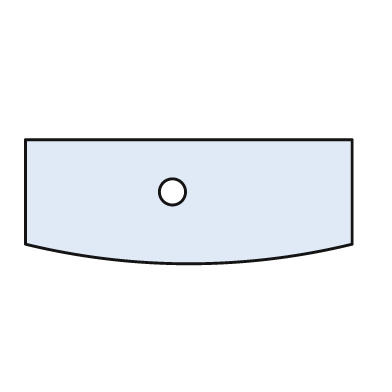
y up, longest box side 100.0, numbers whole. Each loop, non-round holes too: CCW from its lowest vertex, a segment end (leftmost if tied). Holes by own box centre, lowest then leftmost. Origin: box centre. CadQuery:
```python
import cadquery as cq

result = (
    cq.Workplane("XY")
    .moveTo(-50.0, -13.0)
    .threePointArc((0.0, -19.0), (50.0, -13.0))
    .lineTo(50.0, 19.0)
    .lineTo(-50.0, 19.0)
    .close()
    .moveTo(-5.0, 3.0)
    .circle(4.0)
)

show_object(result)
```